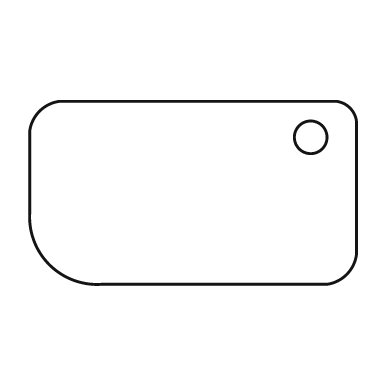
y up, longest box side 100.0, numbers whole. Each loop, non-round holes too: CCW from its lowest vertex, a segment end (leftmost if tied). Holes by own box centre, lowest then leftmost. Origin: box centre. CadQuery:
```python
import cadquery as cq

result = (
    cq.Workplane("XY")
    .moveTo(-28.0, -28.0)
    .lineTo(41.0, -28.0)
    .threePointArc((47.0, -25.0), (50.0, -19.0))
    .lineTo(50.0, 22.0)
    .threePointArc((48.0, 26.0), (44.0, 28.0))
    .lineTo(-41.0, 28.0)
    .threePointArc((-47.0, 25.0), (-50.0, 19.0))
    .lineTo(-50.0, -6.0)
    .threePointArc((-44.0, -22.0), (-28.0, -28.0))
    .close()
    .moveTo(36.0, 17.0)
    .circle(5.0)
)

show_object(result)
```